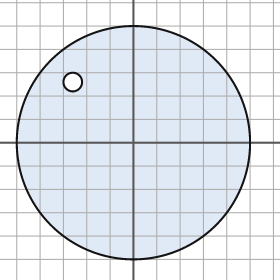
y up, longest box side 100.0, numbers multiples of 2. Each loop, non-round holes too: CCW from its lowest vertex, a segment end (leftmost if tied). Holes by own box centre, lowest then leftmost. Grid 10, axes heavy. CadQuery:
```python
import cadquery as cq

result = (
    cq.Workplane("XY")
    .moveTo(0.0, 0.0)
    .circle(50.0)
    .moveTo(-26.0, 26.0)
    .circle(4.0)
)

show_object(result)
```